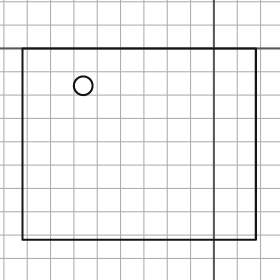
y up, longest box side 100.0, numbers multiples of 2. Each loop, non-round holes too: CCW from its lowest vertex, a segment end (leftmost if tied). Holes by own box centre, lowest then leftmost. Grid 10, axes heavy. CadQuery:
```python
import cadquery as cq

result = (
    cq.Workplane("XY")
    .moveTo(-82.0, -82.0)
    .lineTo(18.0, -82.0)
    .lineTo(18.0, 0.0)
    .lineTo(-82.0, 0.0)
    .close()
    .moveTo(-56.0, -16.0)
    .circle(4.0)
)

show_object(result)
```